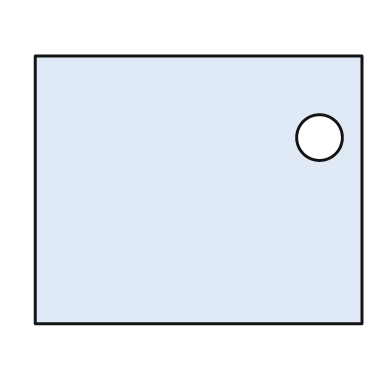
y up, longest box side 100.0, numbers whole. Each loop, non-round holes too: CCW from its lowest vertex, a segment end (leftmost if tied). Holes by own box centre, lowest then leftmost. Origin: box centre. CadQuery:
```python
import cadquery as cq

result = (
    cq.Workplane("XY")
    .moveTo(-50.0, -41.0)
    .lineTo(50.0, -41.0)
    .lineTo(50.0, 41.0)
    .lineTo(-50.0, 41.0)
    .close()
    .moveTo(37.0, 16.0)
    .circle(7.0)
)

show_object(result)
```